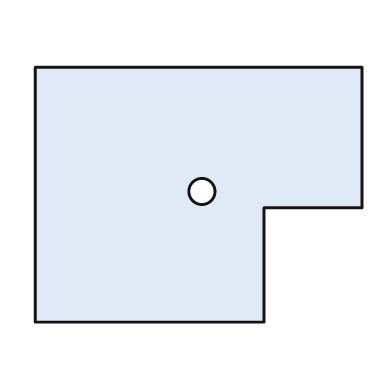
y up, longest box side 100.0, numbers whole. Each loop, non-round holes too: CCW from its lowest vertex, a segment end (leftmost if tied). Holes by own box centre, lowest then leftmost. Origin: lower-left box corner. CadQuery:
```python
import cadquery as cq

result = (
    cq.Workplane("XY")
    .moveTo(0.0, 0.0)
    .lineTo(70.0, 0.0)
    .lineTo(70.0, 35.0)
    .lineTo(100.0, 35.0)
    .lineTo(100.0, 78.0)
    .lineTo(0.0, 78.0)
    .close()
    .moveTo(51.0, 40.0)
    .circle(4.0)
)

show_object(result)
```